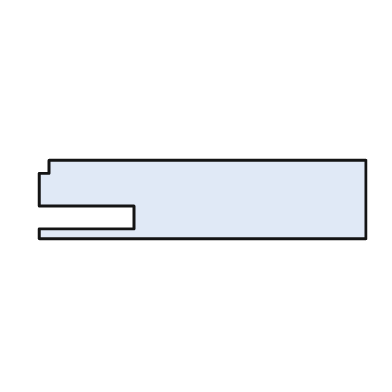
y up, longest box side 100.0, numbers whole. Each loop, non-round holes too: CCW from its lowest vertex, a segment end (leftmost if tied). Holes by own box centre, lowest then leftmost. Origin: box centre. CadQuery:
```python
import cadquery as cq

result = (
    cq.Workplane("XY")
    .moveTo(-50.0, -12.0)
    .lineTo(50.0, -12.0)
    .lineTo(50.0, 12.0)
    .lineTo(-47.0, 12.0)
    .lineTo(-47.0, 8.0)
    .lineTo(-50.0, 8.0)
    .lineTo(-50.0, -2.0)
    .lineTo(-21.0, -2.0)
    .lineTo(-21.0, -9.0)
    .lineTo(-50.0, -9.0)
    .close()
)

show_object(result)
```